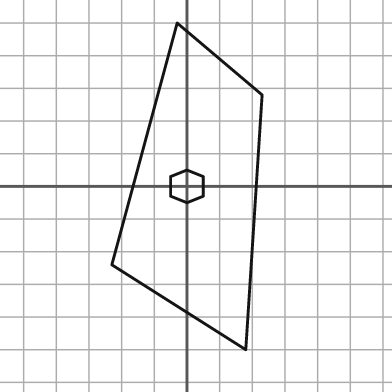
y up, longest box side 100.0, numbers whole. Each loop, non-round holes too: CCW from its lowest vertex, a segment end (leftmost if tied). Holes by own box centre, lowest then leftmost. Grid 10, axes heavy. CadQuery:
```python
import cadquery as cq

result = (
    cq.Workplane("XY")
    .moveTo(18.0, -50.0)
    .lineTo(23.0, 28.0)
    .lineTo(-3.0, 50.0)
    .lineTo(-23.0, -24.0)
    .close()
    .moveTo(0.0, -5.0)
    .lineTo(5.0, -3.0)
    .lineTo(5.0, 3.0)
    .lineTo(0.0, 5.0)
    .lineTo(-5.0, 3.0)
    .lineTo(-5.0, -3.0)
    .close()
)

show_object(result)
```